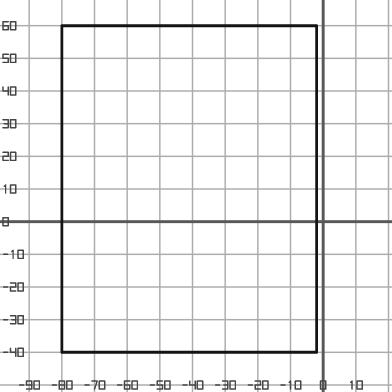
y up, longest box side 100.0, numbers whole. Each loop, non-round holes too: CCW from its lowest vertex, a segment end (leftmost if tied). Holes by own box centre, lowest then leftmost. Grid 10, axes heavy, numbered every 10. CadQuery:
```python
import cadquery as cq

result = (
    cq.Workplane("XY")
    .moveTo(-80.0, -40.0)
    .lineTo(-2.0, -40.0)
    .lineTo(-2.0, 60.0)
    .lineTo(-80.0, 60.0)
    .close()
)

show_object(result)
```